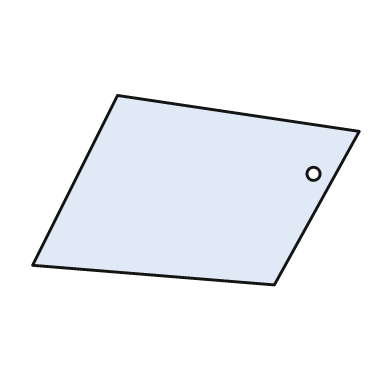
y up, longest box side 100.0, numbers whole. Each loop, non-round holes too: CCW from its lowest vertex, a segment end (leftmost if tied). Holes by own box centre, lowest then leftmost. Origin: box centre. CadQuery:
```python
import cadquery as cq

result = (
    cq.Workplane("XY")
    .moveTo(24.0, -29.0)
    .lineTo(50.0, 18.0)
    .lineTo(-24.0, 29.0)
    .lineTo(-50.0, -23.0)
    .close()
    .moveTo(36.0, 5.0)
    .circle(2.0)
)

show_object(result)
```